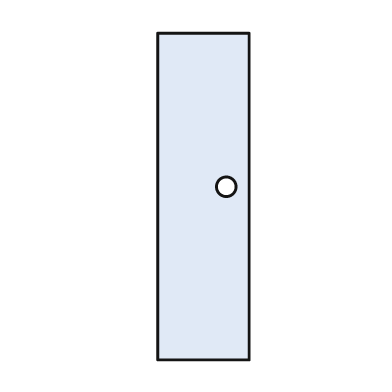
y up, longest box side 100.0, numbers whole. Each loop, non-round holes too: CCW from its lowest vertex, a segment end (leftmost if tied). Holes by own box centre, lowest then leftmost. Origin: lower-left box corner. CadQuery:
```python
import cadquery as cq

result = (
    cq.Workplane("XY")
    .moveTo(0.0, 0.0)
    .lineTo(28.0, 0.0)
    .lineTo(28.0, 100.0)
    .lineTo(0.0, 100.0)
    .close()
    .moveTo(21.0, 53.0)
    .circle(3.0)
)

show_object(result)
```